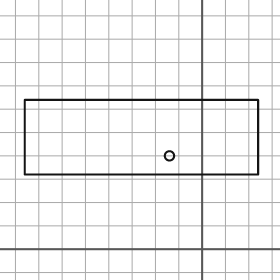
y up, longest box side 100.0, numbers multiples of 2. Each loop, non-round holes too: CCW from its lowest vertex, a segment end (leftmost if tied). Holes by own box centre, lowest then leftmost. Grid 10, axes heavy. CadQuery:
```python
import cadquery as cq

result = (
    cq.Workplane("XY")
    .moveTo(-76.0, 32.0)
    .lineTo(24.0, 32.0)
    .lineTo(24.0, 64.0)
    .lineTo(-76.0, 64.0)
    .close()
    .moveTo(-14.0, 40.0)
    .circle(2.0)
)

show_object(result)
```